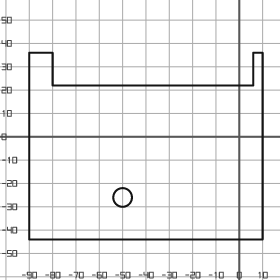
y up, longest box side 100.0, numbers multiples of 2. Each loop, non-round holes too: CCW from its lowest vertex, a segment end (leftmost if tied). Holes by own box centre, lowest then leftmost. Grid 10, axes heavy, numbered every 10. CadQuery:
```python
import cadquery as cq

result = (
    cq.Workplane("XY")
    .moveTo(-90.0, -44.0)
    .lineTo(10.0, -44.0)
    .lineTo(10.0, 36.0)
    .lineTo(6.0, 36.0)
    .lineTo(6.0, 22.0)
    .lineTo(-80.0, 22.0)
    .lineTo(-80.0, 36.0)
    .lineTo(-90.0, 36.0)
    .close()
    .moveTo(-50.0, -26.0)
    .circle(4.0)
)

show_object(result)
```